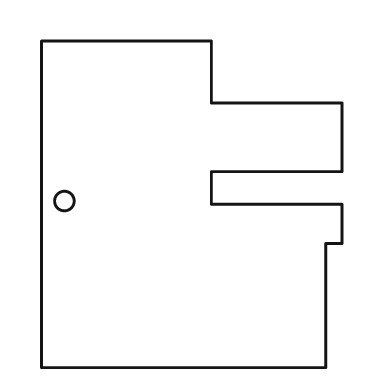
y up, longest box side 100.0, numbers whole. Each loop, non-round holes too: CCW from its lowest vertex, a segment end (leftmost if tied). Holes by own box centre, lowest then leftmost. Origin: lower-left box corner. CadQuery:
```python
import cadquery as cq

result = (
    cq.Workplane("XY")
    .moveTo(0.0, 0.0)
    .lineTo(87.0, 0.0)
    .lineTo(87.0, 38.0)
    .lineTo(92.0, 38.0)
    .lineTo(92.0, 50.0)
    .lineTo(52.0, 50.0)
    .lineTo(52.0, 60.0)
    .lineTo(92.0, 60.0)
    .lineTo(92.0, 81.0)
    .lineTo(52.0, 81.0)
    .lineTo(52.0, 100.0)
    .lineTo(0.0, 100.0)
    .close()
    .moveTo(7.0, 51.0)
    .circle(3.0)
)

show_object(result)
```